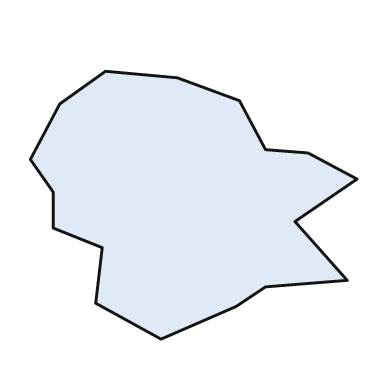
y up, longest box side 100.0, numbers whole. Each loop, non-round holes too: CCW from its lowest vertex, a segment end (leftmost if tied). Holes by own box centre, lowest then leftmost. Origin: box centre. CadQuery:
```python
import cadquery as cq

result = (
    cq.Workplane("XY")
    .moveTo(-10.0, -41.0)
    .lineTo(13.0, -31.0)
    .lineTo(22.0, -25.0)
    .lineTo(47.0, -23.0)
    .lineTo(31.0, -5.0)
    .lineTo(50.0, 8.0)
    .lineTo(35.0, 16.0)
    .lineTo(22.0, 17.0)
    .lineTo(14.0, 32.0)
    .lineTo(-5.0, 39.0)
    .lineTo(-27.0, 41.0)
    .lineTo(-41.0, 31.0)
    .lineTo(-50.0, 14.0)
    .lineTo(-43.0, 4.0)
    .lineTo(-43.0, -7.0)
    .lineTo(-28.0, -13.0)
    .lineTo(-30.0, -30.0)
    .close()
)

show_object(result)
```